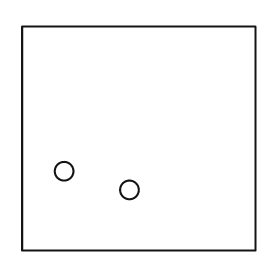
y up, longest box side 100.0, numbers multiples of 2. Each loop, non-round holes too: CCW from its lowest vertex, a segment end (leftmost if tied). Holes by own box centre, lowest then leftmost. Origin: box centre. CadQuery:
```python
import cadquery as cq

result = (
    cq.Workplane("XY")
    .moveTo(-50.0, -48.0)
    .lineTo(50.0, -48.0)
    .lineTo(50.0, 48.0)
    .lineTo(-50.0, 48.0)
    .close()
    .moveTo(-4.0, -22.0)
    .circle(4.0)
    .moveTo(-32.0, -14.0)
    .circle(4.0)
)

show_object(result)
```